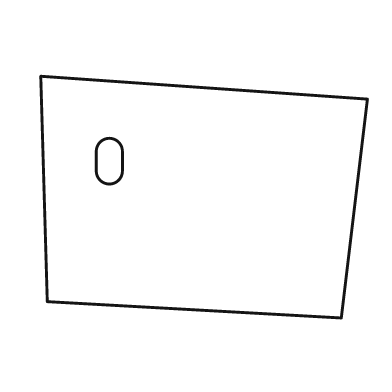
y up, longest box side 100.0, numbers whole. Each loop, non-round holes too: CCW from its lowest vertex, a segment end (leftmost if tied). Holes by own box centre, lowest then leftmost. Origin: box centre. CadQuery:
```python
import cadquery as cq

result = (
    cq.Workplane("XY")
    .moveTo(42.0, -37.0)
    .lineTo(50.0, 30.0)
    .lineTo(-50.0, 37.0)
    .lineTo(-48.0, -32.0)
    .close()
    .moveTo(-33.0, 8.0)
    .threePointArc((-29.0, 4.0), (-25.0, 8.0))
    .lineTo(-25.0, 14.0)
    .threePointArc((-29.0, 18.0), (-33.0, 14.0))
    .close()
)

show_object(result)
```